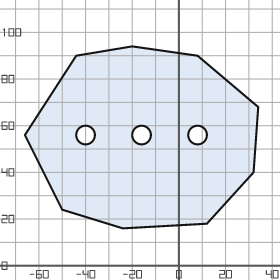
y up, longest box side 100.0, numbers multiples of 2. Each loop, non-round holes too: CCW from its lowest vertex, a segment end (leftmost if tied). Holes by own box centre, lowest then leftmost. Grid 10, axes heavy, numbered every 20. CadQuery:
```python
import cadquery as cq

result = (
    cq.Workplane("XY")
    .moveTo(-24.0, 16.0)
    .lineTo(12.0, 18.0)
    .lineTo(32.0, 40.0)
    .lineTo(34.0, 68.0)
    .lineTo(8.0, 90.0)
    .lineTo(-20.0, 94.0)
    .lineTo(-44.0, 90.0)
    .lineTo(-66.0, 56.0)
    .lineTo(-50.0, 24.0)
    .close()
    .moveTo(-40.0, 56.0)
    .circle(4.0)
    .moveTo(-16.0, 56.0)
    .circle(4.0)
    .moveTo(8.0, 56.0)
    .circle(4.0)
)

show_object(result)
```